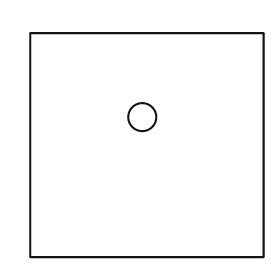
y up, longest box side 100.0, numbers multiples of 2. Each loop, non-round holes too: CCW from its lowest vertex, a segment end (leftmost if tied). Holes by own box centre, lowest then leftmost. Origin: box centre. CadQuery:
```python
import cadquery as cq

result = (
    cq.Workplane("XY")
    .moveTo(-50.0, -48.0)
    .lineTo(50.0, -48.0)
    .lineTo(50.0, 48.0)
    .lineTo(-50.0, 48.0)
    .close()
    .moveTo(-2.0, 12.0)
    .circle(6.0)
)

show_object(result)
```